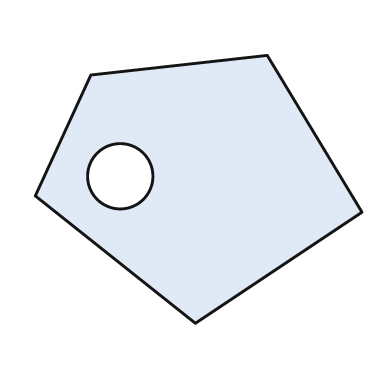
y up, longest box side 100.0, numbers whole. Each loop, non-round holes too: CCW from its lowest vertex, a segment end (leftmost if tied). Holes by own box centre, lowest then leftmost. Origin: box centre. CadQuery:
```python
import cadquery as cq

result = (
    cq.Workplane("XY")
    .moveTo(-1.0, -41.0)
    .lineTo(50.0, -7.0)
    .lineTo(21.0, 41.0)
    .lineTo(-33.0, 35.0)
    .lineTo(-50.0, -2.0)
    .close()
    .moveTo(-24.0, 4.0)
    .circle(10.0)
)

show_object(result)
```